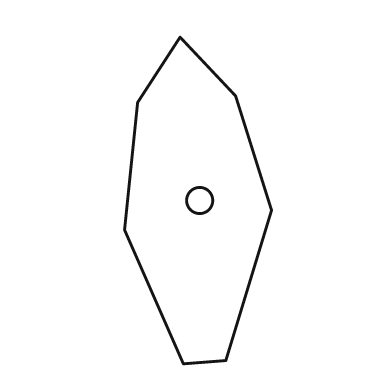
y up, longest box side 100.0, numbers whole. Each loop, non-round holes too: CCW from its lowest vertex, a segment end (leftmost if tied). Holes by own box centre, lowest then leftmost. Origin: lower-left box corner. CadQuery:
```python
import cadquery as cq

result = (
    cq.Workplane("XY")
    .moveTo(18.0, 0.0)
    .lineTo(31.0, 1.0)
    .lineTo(45.0, 47.0)
    .lineTo(34.0, 82.0)
    .lineTo(17.0, 100.0)
    .lineTo(4.0, 80.0)
    .lineTo(0.0, 41.0)
    .close()
    .moveTo(23.0, 50.0)
    .circle(4.0)
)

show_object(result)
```